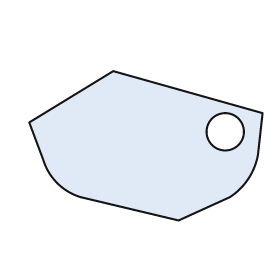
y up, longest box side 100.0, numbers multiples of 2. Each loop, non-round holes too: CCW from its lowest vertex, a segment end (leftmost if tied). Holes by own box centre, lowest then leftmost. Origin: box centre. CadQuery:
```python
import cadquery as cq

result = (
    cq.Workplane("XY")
    .moveTo(14.0, -32.0)
    .lineTo(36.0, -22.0)
    .threePointArc((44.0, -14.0), (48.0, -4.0))
    .lineTo(50.0, 14.0)
    .lineTo(-14.0, 32.0)
    .lineTo(-50.0, 10.0)
    .lineTo(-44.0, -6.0)
    .threePointArc((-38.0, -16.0), (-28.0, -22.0))
    .close()
    .moveTo(34.0, 6.0)
    .circle(8.0)
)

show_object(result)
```